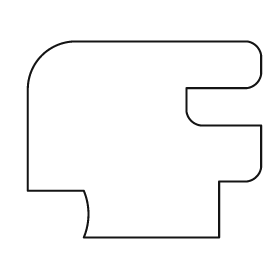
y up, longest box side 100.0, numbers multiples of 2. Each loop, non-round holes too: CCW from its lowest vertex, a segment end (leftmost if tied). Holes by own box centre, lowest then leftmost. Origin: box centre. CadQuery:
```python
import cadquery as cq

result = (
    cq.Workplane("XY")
    .moveTo(-26.0, -42.0)
    .lineTo(32.0, -42.0)
    .lineTo(32.0, -18.0)
    .lineTo(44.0, -18.0)
    .threePointArc((48.0, -16.0), (50.0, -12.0))
    .lineTo(50.0, 6.0)
    .lineTo(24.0, 6.0)
    .threePointArc((20.0, 8.0), (18.0, 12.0))
    .lineTo(18.0, 22.0)
    .lineTo(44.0, 22.0)
    .threePointArc((48.0, 24.0), (50.0, 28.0))
    .lineTo(50.0, 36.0)
    .threePointArc((48.0, 40.0), (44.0, 42.0))
    .lineTo(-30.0, 42.0)
    .threePointArc((-44.0, 36.0), (-50.0, 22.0))
    .lineTo(-50.0, -22.0)
    .lineTo(-26.0, -22.0)
    .threePointArc((-24.0, -32.0), (-26.0, -42.0))
    .close()
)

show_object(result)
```